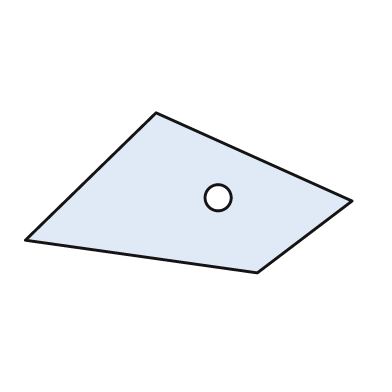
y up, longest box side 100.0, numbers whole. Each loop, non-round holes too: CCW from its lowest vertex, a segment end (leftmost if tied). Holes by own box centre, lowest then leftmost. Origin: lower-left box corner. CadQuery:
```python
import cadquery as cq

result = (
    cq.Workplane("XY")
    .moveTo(71.0, 0.0)
    .lineTo(100.0, 22.0)
    .lineTo(40.0, 49.0)
    .lineTo(0.0, 10.0)
    .close()
    .moveTo(59.0, 23.0)
    .circle(4.0)
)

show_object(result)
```